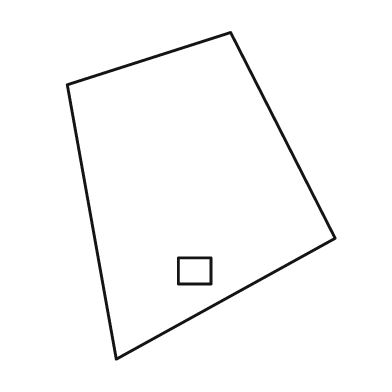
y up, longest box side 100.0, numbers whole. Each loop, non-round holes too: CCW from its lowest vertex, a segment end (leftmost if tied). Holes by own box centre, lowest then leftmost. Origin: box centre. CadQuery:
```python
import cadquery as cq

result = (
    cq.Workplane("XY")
    .moveTo(-26.0, -50.0)
    .lineTo(41.0, -13.0)
    .lineTo(9.0, 50.0)
    .lineTo(-41.0, 34.0)
    .close()
    .moveTo(-7.0, -27.0)
    .lineTo(3.0, -27.0)
    .lineTo(3.0, -19.0)
    .lineTo(-7.0, -19.0)
    .close()
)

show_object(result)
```